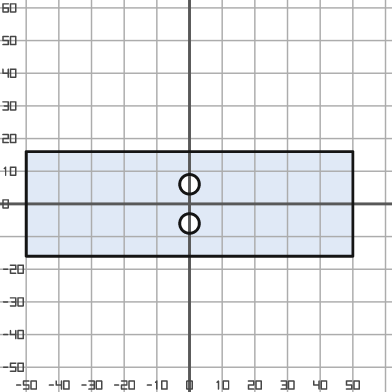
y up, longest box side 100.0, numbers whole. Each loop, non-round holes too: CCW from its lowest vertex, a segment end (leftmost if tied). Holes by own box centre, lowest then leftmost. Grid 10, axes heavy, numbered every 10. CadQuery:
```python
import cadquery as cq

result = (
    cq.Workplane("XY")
    .moveTo(-50.0, -16.0)
    .lineTo(50.0, -16.0)
    .lineTo(50.0, 16.0)
    .lineTo(-50.0, 16.0)
    .close()
    .moveTo(0.0, -6.0)
    .circle(3.0)
    .moveTo(0.0, 6.0)
    .circle(3.0)
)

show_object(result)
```